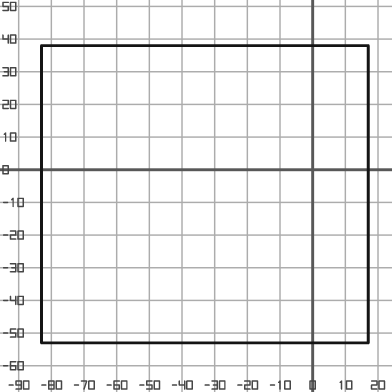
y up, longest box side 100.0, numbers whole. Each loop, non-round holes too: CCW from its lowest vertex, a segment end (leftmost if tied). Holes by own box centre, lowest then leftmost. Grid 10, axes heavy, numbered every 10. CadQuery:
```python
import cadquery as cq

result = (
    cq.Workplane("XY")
    .moveTo(-83.0, -53.0)
    .lineTo(17.0, -53.0)
    .lineTo(17.0, 38.0)
    .lineTo(-83.0, 38.0)
    .close()
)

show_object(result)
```